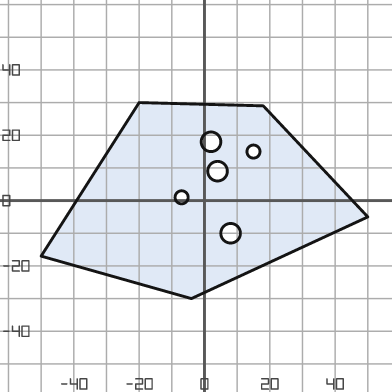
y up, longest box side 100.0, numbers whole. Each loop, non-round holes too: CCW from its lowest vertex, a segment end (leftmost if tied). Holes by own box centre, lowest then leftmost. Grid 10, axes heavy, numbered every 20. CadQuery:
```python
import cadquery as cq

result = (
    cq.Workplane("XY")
    .moveTo(-4.0, -30.0)
    .lineTo(50.0, -5.0)
    .lineTo(18.0, 29.0)
    .lineTo(-20.0, 30.0)
    .lineTo(-50.0, -17.0)
    .close()
    .moveTo(8.0, -10.0)
    .circle(3.0)
    .moveTo(-7.0, 1.0)
    .circle(2.0)
    .moveTo(4.0, 9.0)
    .circle(3.0)
    .moveTo(15.0, 15.0)
    .circle(2.0)
    .moveTo(2.0, 18.0)
    .circle(3.0)
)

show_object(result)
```